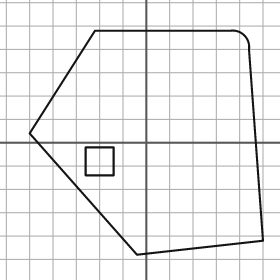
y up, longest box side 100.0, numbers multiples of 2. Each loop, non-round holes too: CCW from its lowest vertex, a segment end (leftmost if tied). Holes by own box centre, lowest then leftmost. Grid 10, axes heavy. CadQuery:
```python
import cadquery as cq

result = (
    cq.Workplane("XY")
    .moveTo(-4.0, -48.0)
    .lineTo(50.0, -42.0)
    .lineTo(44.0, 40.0)
    .threePointArc((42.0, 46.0), (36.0, 48.0))
    .lineTo(-22.0, 48.0)
    .lineTo(-50.0, 4.0)
    .close()
    .moveTo(-26.0, -14.0)
    .lineTo(-14.0, -14.0)
    .lineTo(-14.0, -2.0)
    .lineTo(-26.0, -2.0)
    .close()
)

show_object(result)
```